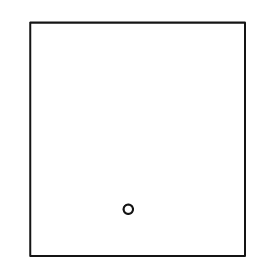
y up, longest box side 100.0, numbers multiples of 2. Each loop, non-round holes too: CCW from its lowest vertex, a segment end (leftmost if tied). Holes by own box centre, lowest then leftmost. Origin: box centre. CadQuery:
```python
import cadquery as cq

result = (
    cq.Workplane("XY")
    .moveTo(-46.0, -50.0)
    .lineTo(46.0, -50.0)
    .lineTo(46.0, 50.0)
    .lineTo(-46.0, 50.0)
    .close()
    .moveTo(-4.0, -30.0)
    .circle(2.0)
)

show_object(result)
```